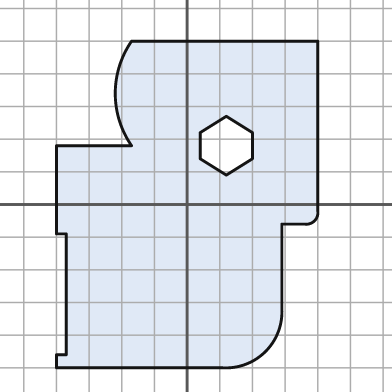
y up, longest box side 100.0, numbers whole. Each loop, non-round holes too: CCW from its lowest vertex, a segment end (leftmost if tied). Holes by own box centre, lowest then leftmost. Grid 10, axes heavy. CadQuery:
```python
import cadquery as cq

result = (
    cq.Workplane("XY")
    .moveTo(-40.0, -50.0)
    .lineTo(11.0, -50.0)
    .threePointArc((24.0, -45.0), (29.0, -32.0))
    .lineTo(29.0, -6.0)
    .lineTo(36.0, -6.0)
    .threePointArc((39.0, -5.0), (40.0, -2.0))
    .lineTo(40.0, 50.0)
    .lineTo(-17.0, 50.0)
    .threePointArc((-22.0, 34.0), (-17.0, 18.0))
    .lineTo(-40.0, 18.0)
    .lineTo(-40.0, -9.0)
    .lineTo(-37.0, -9.0)
    .lineTo(-37.0, -46.0)
    .lineTo(-40.0, -46.0)
    .close()
    .moveTo(12.0, 9.0)
    .lineTo(20.0, 14.0)
    .lineTo(20.0, 22.0)
    .lineTo(12.0, 27.0)
    .lineTo(4.0, 22.0)
    .lineTo(4.0, 14.0)
    .close()
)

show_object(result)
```